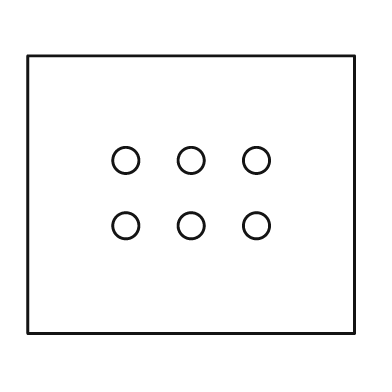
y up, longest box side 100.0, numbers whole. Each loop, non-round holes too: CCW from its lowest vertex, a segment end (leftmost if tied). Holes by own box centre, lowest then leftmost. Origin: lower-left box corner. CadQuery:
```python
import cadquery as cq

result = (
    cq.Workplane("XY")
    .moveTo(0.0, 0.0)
    .lineTo(100.0, 0.0)
    .lineTo(100.0, 85.0)
    .lineTo(0.0, 85.0)
    .close()
    .moveTo(30.0, 33.0)
    .circle(4.0)
    .moveTo(50.0, 33.0)
    .circle(4.0)
    .moveTo(70.0, 33.0)
    .circle(4.0)
    .moveTo(30.0, 53.0)
    .circle(4.0)
    .moveTo(50.0, 53.0)
    .circle(4.0)
    .moveTo(70.0, 53.0)
    .circle(4.0)
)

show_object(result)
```